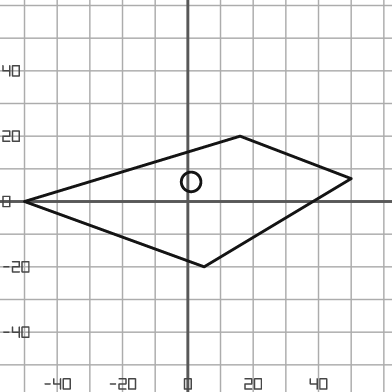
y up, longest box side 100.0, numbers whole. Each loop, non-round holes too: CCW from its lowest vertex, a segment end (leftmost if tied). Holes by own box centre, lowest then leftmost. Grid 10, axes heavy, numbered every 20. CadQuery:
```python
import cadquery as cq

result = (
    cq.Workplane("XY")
    .moveTo(5.0, -20.0)
    .lineTo(50.0, 7.0)
    .lineTo(16.0, 20.0)
    .lineTo(-50.0, 0.0)
    .close()
    .moveTo(1.0, 6.0)
    .circle(3.0)
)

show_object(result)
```